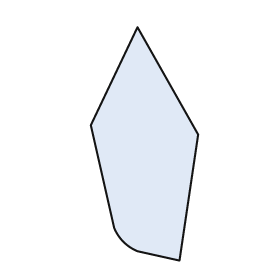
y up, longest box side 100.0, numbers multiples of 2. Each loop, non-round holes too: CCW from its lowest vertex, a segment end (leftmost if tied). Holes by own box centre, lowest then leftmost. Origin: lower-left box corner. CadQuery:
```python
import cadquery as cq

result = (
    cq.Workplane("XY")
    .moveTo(38.0, 0.0)
    .lineTo(46.0, 54.0)
    .lineTo(20.0, 100.0)
    .lineTo(0.0, 58.0)
    .lineTo(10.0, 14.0)
    .threePointArc((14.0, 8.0), (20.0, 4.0))
    .close()
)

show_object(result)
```